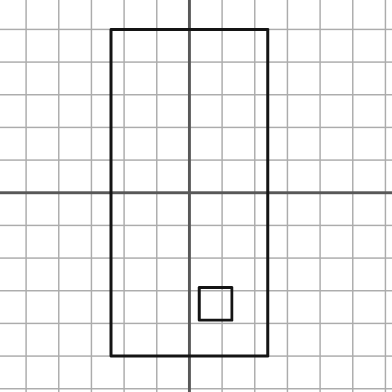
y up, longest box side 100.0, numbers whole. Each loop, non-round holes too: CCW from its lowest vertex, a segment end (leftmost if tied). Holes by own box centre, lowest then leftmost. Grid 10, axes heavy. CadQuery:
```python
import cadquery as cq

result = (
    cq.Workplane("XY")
    .moveTo(-24.0, -50.0)
    .lineTo(24.0, -50.0)
    .lineTo(24.0, 50.0)
    .lineTo(-24.0, 50.0)
    .close()
    .moveTo(3.0, -39.0)
    .lineTo(13.0, -39.0)
    .lineTo(13.0, -29.0)
    .lineTo(3.0, -29.0)
    .close()
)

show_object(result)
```